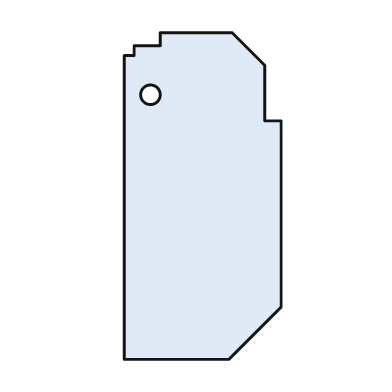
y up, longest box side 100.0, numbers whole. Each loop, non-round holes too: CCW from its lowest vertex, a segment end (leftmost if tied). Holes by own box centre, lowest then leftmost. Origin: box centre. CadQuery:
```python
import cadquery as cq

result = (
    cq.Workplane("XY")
    .moveTo(-24.0, -50.0)
    .lineTo(8.0, -50.0)
    .lineTo(24.0, -34.0)
    .lineTo(24.0, 23.0)
    .lineTo(19.0, 23.0)
    .lineTo(19.0, 40.0)
    .lineTo(9.0, 50.0)
    .lineTo(-13.0, 50.0)
    .lineTo(-13.0, 46.0)
    .lineTo(-21.0, 46.0)
    .lineTo(-21.0, 43.0)
    .lineTo(-24.0, 43.0)
    .close()
    .moveTo(-16.0, 31.0)
    .circle(3.0)
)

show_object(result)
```